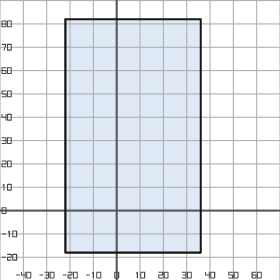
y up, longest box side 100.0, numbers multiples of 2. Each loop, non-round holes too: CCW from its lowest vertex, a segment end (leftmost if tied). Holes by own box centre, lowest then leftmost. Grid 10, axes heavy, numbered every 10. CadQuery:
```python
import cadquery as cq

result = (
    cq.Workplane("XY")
    .moveTo(-22.0, -18.0)
    .lineTo(36.0, -18.0)
    .lineTo(36.0, 82.0)
    .lineTo(-22.0, 82.0)
    .close()
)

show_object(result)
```